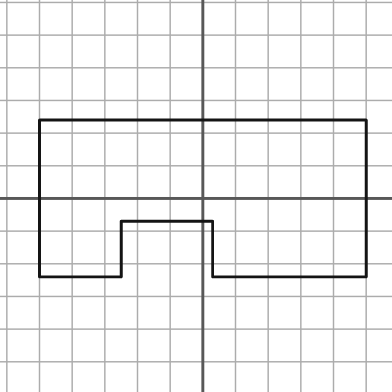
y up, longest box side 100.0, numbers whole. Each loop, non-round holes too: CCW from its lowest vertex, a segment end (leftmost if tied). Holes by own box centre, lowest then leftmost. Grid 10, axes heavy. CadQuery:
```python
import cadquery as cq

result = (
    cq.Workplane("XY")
    .moveTo(-50.0, -24.0)
    .lineTo(-25.0, -24.0)
    .lineTo(-25.0, -7.0)
    .lineTo(3.0, -7.0)
    .lineTo(3.0, -24.0)
    .lineTo(50.0, -24.0)
    .lineTo(50.0, 24.0)
    .lineTo(-50.0, 24.0)
    .close()
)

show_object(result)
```